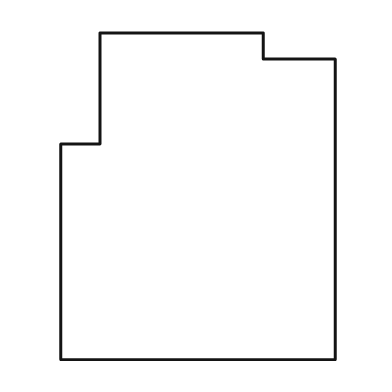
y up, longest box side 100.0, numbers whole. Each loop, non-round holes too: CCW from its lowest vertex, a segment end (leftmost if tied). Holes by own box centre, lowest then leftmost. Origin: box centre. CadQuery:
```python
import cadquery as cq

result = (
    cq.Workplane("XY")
    .moveTo(-42.0, -50.0)
    .lineTo(42.0, -50.0)
    .lineTo(42.0, 42.0)
    .lineTo(20.0, 42.0)
    .lineTo(20.0, 50.0)
    .lineTo(-30.0, 50.0)
    .lineTo(-30.0, 16.0)
    .lineTo(-42.0, 16.0)
    .close()
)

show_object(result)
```